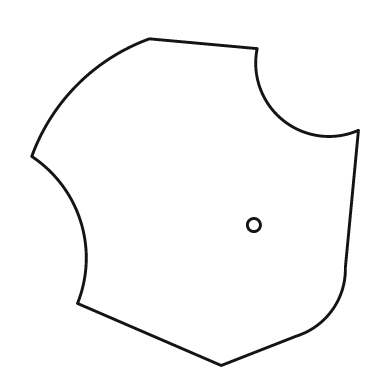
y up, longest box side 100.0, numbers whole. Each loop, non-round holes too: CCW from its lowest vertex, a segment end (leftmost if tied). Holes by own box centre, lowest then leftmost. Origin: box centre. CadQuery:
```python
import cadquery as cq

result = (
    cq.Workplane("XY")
    .moveTo(8.0, -50.0)
    .lineTo(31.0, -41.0)
    .threePointArc((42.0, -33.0), (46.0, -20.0))
    .lineTo(50.0, 22.0)
    .threePointArc((27.0, 25.0), (19.0, 47.0))
    .lineTo(-14.0, 50.0)
    .threePointArc((-36.0, 36.0), (-50.0, 14.0))
    .threePointArc((-35.0, -6.0), (-36.0, -31.0))
    .close()
    .moveTo(18.0, -7.0)
    .circle(2.0)
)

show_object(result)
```